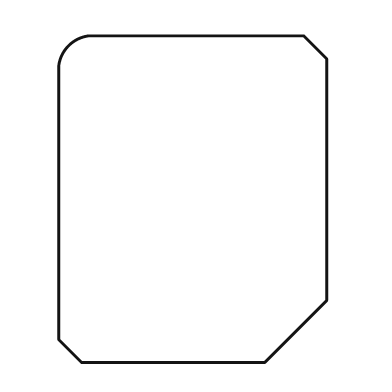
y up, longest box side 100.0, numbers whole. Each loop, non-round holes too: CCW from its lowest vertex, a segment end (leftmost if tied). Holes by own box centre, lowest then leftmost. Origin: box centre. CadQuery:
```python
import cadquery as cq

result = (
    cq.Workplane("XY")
    .moveTo(-34.0, -50.0)
    .lineTo(22.0, -50.0)
    .lineTo(41.0, -31.0)
    .lineTo(41.0, 43.0)
    .lineTo(34.0, 50.0)
    .lineTo(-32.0, 50.0)
    .threePointArc((-38.0, 47.0), (-41.0, 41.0))
    .lineTo(-41.0, -43.0)
    .close()
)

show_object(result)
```